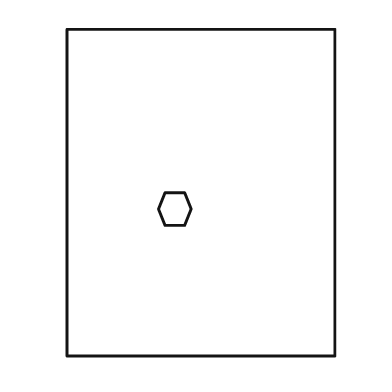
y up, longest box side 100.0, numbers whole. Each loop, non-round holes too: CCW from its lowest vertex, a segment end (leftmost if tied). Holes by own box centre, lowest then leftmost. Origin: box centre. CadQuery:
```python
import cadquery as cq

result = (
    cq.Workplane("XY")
    .moveTo(-41.0, -50.0)
    .lineTo(41.0, -50.0)
    .lineTo(41.0, 50.0)
    .lineTo(-41.0, 50.0)
    .close()
    .moveTo(-11.0, -10.0)
    .lineTo(-5.0, -10.0)
    .lineTo(-3.0, -5.0)
    .lineTo(-5.0, 0.0)
    .lineTo(-11.0, 0.0)
    .lineTo(-13.0, -5.0)
    .close()
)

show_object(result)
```